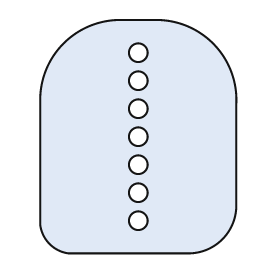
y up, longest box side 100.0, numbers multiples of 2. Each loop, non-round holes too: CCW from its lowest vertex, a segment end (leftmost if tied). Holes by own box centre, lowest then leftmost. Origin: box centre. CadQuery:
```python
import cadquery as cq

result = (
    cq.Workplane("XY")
    .moveTo(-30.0, -50.0)
    .lineTo(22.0, -50.0)
    .threePointArc((36.0, -44.0), (42.0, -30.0))
    .lineTo(42.0, 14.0)
    .threePointArc((32.0, 40.0), (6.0, 50.0))
    .lineTo(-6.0, 50.0)
    .threePointArc((-32.0, 40.0), (-42.0, 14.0))
    .lineTo(-42.0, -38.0)
    .threePointArc((-38.0, -46.0), (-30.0, -50.0))
    .close()
    .moveTo(0.0, -36.0)
    .circle(4.0)
    .moveTo(0.0, -24.0)
    .circle(4.0)
    .moveTo(0.0, -12.0)
    .circle(4.0)
    .moveTo(0.0, 0.0)
    .circle(4.0)
    .moveTo(0.0, 12.0)
    .circle(4.0)
    .moveTo(0.0, 24.0)
    .circle(4.0)
    .moveTo(0.0, 36.0)
    .circle(4.0)
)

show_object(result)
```